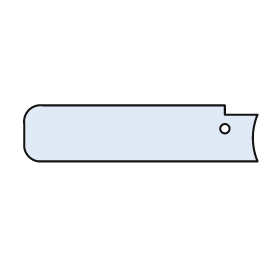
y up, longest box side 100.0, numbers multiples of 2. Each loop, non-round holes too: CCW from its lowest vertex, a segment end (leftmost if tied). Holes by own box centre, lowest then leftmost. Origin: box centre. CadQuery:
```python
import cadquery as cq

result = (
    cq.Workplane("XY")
    .moveTo(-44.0, -12.0)
    .lineTo(50.0, -12.0)
    .threePointArc((48.0, -2.0), (50.0, 8.0))
    .lineTo(36.0, 8.0)
    .lineTo(36.0, 12.0)
    .lineTo(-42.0, 12.0)
    .threePointArc((-48.0, 10.0), (-50.0, 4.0))
    .lineTo(-50.0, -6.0)
    .threePointArc((-48.0, -10.0), (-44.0, -12.0))
    .close()
    .moveTo(36.0, 2.0)
    .circle(2.0)
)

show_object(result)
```